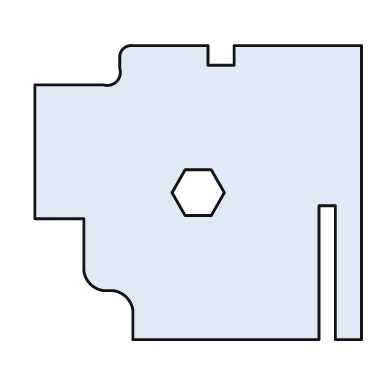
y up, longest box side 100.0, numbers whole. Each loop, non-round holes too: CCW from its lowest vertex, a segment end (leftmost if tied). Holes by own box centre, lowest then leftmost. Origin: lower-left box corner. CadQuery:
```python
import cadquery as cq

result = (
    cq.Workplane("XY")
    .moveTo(30.0, 0.0)
    .lineTo(87.0, 0.0)
    .lineTo(87.0, 41.0)
    .lineTo(92.0, 41.0)
    .lineTo(92.0, 0.0)
    .lineTo(100.0, 0.0)
    .lineTo(100.0, 90.0)
    .lineTo(61.0, 90.0)
    .lineTo(61.0, 84.0)
    .lineTo(53.0, 84.0)
    .lineTo(53.0, 90.0)
    .lineTo(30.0, 90.0)
    .threePointArc((27.0, 89.0), (26.0, 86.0))
    .lineTo(26.0, 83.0)
    .threePointArc((25.0, 79.0), (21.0, 78.0))
    .lineTo(0.0, 78.0)
    .lineTo(0.0, 37.0)
    .lineTo(15.0, 37.0)
    .lineTo(15.0, 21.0)
    .threePointArc((17.0, 17.0), (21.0, 15.0))
    .lineTo(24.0, 15.0)
    .threePointArc((28.0, 13.0), (30.0, 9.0))
    .close()
    .moveTo(46.0, 38.0)
    .lineTo(54.0, 38.0)
    .lineTo(58.0, 45.0)
    .lineTo(54.0, 52.0)
    .lineTo(46.0, 52.0)
    .lineTo(42.0, 45.0)
    .close()
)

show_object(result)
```